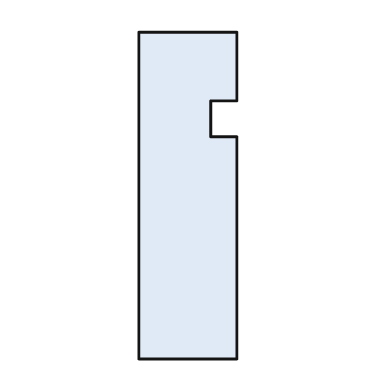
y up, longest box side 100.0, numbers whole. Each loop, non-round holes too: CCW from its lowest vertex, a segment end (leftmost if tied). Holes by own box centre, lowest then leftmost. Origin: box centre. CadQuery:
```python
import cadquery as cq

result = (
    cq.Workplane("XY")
    .moveTo(-15.0, -50.0)
    .lineTo(15.0, -50.0)
    .lineTo(15.0, 18.0)
    .lineTo(7.0, 18.0)
    .lineTo(7.0, 29.0)
    .lineTo(15.0, 29.0)
    .lineTo(15.0, 50.0)
    .lineTo(-15.0, 50.0)
    .close()
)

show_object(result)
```